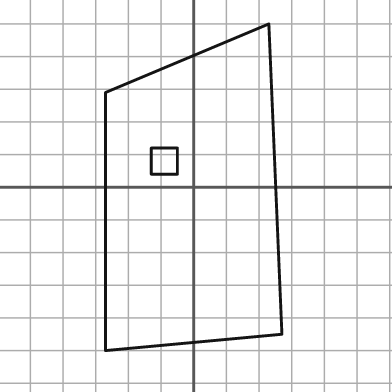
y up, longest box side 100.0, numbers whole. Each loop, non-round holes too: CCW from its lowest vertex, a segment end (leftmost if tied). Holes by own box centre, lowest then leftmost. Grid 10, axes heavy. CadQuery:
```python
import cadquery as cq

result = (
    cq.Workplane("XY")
    .moveTo(-27.0, -50.0)
    .lineTo(27.0, -45.0)
    .lineTo(23.0, 50.0)
    .lineTo(-27.0, 29.0)
    .close()
    .moveTo(-13.0, 4.0)
    .lineTo(-5.0, 4.0)
    .lineTo(-5.0, 12.0)
    .lineTo(-13.0, 12.0)
    .close()
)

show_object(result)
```